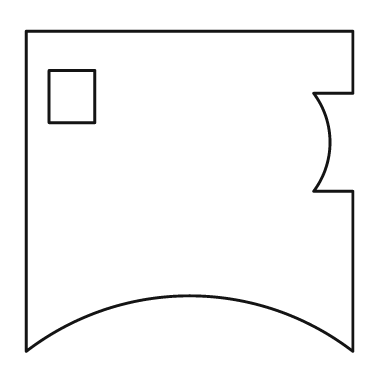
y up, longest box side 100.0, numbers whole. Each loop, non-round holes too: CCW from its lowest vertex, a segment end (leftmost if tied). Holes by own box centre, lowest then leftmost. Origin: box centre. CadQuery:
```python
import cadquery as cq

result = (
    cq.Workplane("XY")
    .moveTo(-50.0, -49.0)
    .threePointArc((0.0, -32.0), (50.0, -49.0))
    .lineTo(50.0, 0.0)
    .lineTo(38.0, 0.0)
    .threePointArc((43.0, 15.0), (38.0, 30.0))
    .lineTo(50.0, 30.0)
    .lineTo(50.0, 49.0)
    .lineTo(-50.0, 49.0)
    .close()
    .moveTo(-43.0, 21.0)
    .lineTo(-29.0, 21.0)
    .lineTo(-29.0, 37.0)
    .lineTo(-43.0, 37.0)
    .close()
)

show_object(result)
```